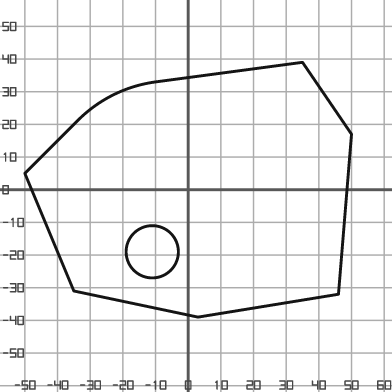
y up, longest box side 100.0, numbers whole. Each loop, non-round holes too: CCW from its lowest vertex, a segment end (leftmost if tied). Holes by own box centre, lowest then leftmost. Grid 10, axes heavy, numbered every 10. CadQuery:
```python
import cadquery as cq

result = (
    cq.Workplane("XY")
    .moveTo(3.0, -39.0)
    .lineTo(46.0, -32.0)
    .lineTo(50.0, 17.0)
    .lineTo(35.0, 39.0)
    .lineTo(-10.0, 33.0)
    .threePointArc((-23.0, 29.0), (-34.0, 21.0))
    .lineTo(-50.0, 5.0)
    .lineTo(-35.0, -31.0)
    .close()
    .moveTo(-11.0, -19.0)
    .circle(8.0)
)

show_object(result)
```